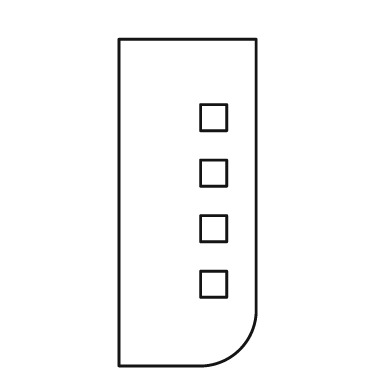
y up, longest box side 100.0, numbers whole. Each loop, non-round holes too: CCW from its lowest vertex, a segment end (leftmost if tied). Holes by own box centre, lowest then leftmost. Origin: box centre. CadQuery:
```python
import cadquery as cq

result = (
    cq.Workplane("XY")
    .moveTo(-21.0, -50.0)
    .lineTo(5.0, -50.0)
    .threePointArc((16.0, -45.0), (21.0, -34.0))
    .lineTo(21.0, 50.0)
    .lineTo(-21.0, 50.0)
    .close()
    .moveTo(4.0, -29.0)
    .lineTo(12.0, -29.0)
    .lineTo(12.0, -21.0)
    .lineTo(4.0, -21.0)
    .close()
    .moveTo(4.0, -12.0)
    .lineTo(12.0, -12.0)
    .lineTo(12.0, -4.0)
    .lineTo(4.0, -4.0)
    .close()
    .moveTo(4.0, 5.0)
    .lineTo(12.0, 5.0)
    .lineTo(12.0, 13.0)
    .lineTo(4.0, 13.0)
    .close()
    .moveTo(4.0, 22.0)
    .lineTo(12.0, 22.0)
    .lineTo(12.0, 30.0)
    .lineTo(4.0, 30.0)
    .close()
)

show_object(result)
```